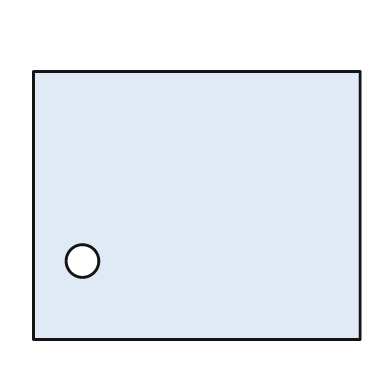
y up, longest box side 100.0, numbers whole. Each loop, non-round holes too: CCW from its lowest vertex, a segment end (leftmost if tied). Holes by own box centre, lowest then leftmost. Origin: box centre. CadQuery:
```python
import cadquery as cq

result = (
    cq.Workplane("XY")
    .moveTo(-50.0, -41.0)
    .lineTo(50.0, -41.0)
    .lineTo(50.0, 41.0)
    .lineTo(-50.0, 41.0)
    .close()
    .moveTo(-35.0, -17.0)
    .circle(5.0)
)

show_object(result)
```